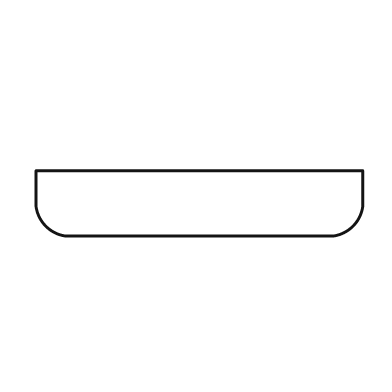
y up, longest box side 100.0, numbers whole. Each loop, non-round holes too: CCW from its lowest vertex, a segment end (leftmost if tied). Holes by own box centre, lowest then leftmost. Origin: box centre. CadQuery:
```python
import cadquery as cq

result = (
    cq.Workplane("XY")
    .moveTo(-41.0, -10.0)
    .lineTo(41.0, -10.0)
    .threePointArc((47.0, -7.0), (50.0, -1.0))
    .lineTo(50.0, 10.0)
    .lineTo(-50.0, 10.0)
    .lineTo(-50.0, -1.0)
    .threePointArc((-47.0, -7.0), (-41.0, -10.0))
    .close()
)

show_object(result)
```